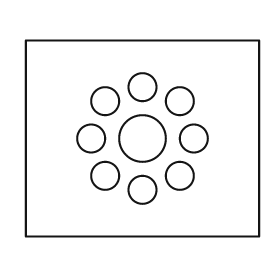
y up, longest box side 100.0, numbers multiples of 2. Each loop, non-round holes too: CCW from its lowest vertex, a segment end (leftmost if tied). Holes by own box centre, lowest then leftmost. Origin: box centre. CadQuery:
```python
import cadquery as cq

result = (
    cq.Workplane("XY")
    .moveTo(-50.0, -42.0)
    .lineTo(50.0, -42.0)
    .lineTo(50.0, 42.0)
    .lineTo(-50.0, 42.0)
    .close()
    .moveTo(0.0, -22.0)
    .circle(6.0)
    .moveTo(-16.0, -16.0)
    .circle(6.0)
    .moveTo(16.0, -16.0)
    .circle(6.0)
    .moveTo(-22.0, 0.0)
    .circle(6.0)
    .moveTo(0.0, 0.0)
    .circle(10.0)
    .moveTo(22.0, 0.0)
    .circle(6.0)
    .moveTo(-16.0, 16.0)
    .circle(6.0)
    .moveTo(16.0, 16.0)
    .circle(6.0)
    .moveTo(0.0, 22.0)
    .circle(6.0)
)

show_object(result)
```